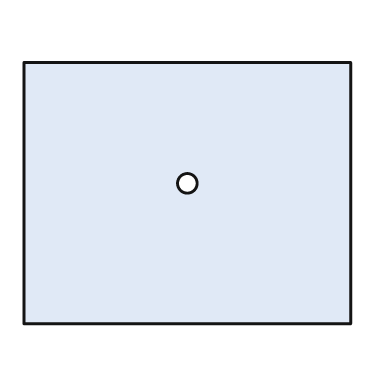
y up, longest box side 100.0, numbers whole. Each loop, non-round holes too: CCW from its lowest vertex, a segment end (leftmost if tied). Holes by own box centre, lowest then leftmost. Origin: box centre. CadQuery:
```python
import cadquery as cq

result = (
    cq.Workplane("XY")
    .moveTo(-50.0, -40.0)
    .lineTo(50.0, -40.0)
    .lineTo(50.0, 40.0)
    .lineTo(-50.0, 40.0)
    .close()
    .moveTo(0.0, 3.0)
    .circle(3.0)
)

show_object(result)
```